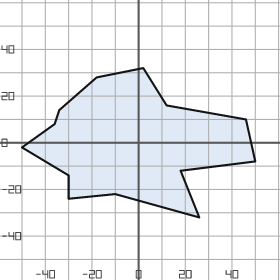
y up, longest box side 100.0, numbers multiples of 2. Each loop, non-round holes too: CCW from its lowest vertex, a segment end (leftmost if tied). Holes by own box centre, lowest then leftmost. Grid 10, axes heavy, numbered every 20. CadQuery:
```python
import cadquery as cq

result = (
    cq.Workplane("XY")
    .moveTo(26.0, -32.0)
    .lineTo(18.0, -12.0)
    .lineTo(50.0, -8.0)
    .lineTo(46.0, 10.0)
    .lineTo(12.0, 16.0)
    .lineTo(2.0, 32.0)
    .lineTo(-18.0, 28.0)
    .lineTo(-34.0, 14.0)
    .lineTo(-36.0, 8.0)
    .lineTo(-50.0, -2.0)
    .lineTo(-30.0, -14.0)
    .lineTo(-30.0, -24.0)
    .lineTo(-10.0, -22.0)
    .close()
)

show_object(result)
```